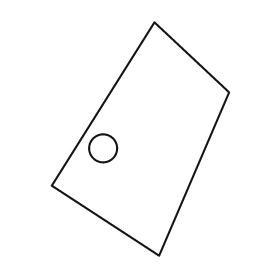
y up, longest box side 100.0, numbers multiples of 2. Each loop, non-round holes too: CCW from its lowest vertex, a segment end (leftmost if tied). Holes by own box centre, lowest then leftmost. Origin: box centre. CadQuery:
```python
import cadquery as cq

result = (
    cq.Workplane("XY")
    .moveTo(8.0, -50.0)
    .lineTo(38.0, 20.0)
    .lineTo(6.0, 50.0)
    .lineTo(-38.0, -20.0)
    .close()
    .moveTo(-16.0, -4.0)
    .circle(6.0)
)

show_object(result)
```